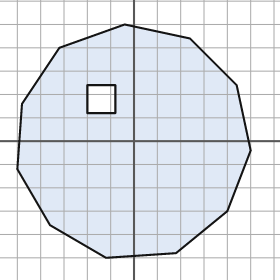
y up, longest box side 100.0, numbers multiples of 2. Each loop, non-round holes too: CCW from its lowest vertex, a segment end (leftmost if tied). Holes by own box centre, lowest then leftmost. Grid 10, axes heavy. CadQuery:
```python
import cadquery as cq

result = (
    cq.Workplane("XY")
    .moveTo(-12.0, -50.0)
    .lineTo(18.0, -48.0)
    .lineTo(40.0, -30.0)
    .lineTo(50.0, -4.0)
    .lineTo(44.0, 24.0)
    .lineTo(24.0, 44.0)
    .lineTo(-4.0, 50.0)
    .lineTo(-32.0, 40.0)
    .lineTo(-48.0, 16.0)
    .lineTo(-50.0, -12.0)
    .lineTo(-36.0, -36.0)
    .close()
    .moveTo(-20.0, 12.0)
    .lineTo(-8.0, 12.0)
    .lineTo(-8.0, 24.0)
    .lineTo(-20.0, 24.0)
    .close()
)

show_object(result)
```